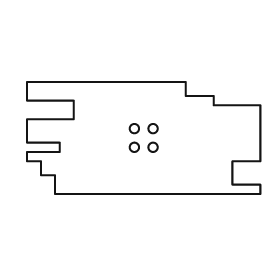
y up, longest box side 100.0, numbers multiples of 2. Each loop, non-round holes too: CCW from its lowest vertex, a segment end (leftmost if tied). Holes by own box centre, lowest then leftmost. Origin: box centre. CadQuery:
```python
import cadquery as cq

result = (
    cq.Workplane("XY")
    .moveTo(-38.0, -24.0)
    .lineTo(50.0, -24.0)
    .lineTo(50.0, -20.0)
    .lineTo(38.0, -20.0)
    .lineTo(38.0, -10.0)
    .lineTo(50.0, -10.0)
    .lineTo(50.0, 14.0)
    .lineTo(30.0, 14.0)
    .lineTo(30.0, 18.0)
    .lineTo(18.0, 18.0)
    .lineTo(18.0, 24.0)
    .lineTo(-50.0, 24.0)
    .lineTo(-50.0, 16.0)
    .lineTo(-30.0, 16.0)
    .lineTo(-30.0, 8.0)
    .lineTo(-50.0, 8.0)
    .lineTo(-50.0, -2.0)
    .lineTo(-36.0, -2.0)
    .lineTo(-36.0, -6.0)
    .lineTo(-50.0, -6.0)
    .lineTo(-50.0, -10.0)
    .lineTo(-44.0, -10.0)
    .lineTo(-44.0, -16.0)
    .lineTo(-38.0, -16.0)
    .close()
    .moveTo(-4.0, -4.0)
    .circle(2.0)
    .moveTo(4.0, -4.0)
    .circle(2.0)
    .moveTo(-4.0, 4.0)
    .circle(2.0)
    .moveTo(4.0, 4.0)
    .circle(2.0)
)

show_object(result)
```